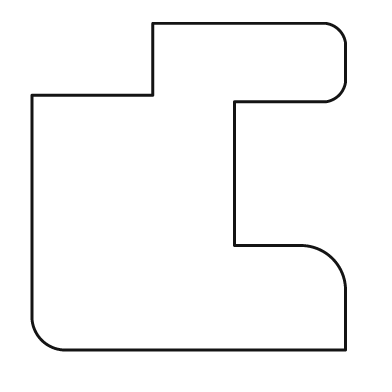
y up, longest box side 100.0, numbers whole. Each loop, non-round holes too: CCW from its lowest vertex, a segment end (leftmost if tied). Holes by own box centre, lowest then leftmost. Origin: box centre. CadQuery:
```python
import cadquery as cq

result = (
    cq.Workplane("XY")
    .moveTo(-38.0, -50.0)
    .lineTo(48.0, -50.0)
    .lineTo(48.0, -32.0)
    .threePointArc((44.0, -22.0), (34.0, -18.0))
    .lineTo(14.0, -18.0)
    .lineTo(14.0, 26.0)
    .lineTo(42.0, 26.0)
    .threePointArc((46.0, 28.0), (48.0, 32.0))
    .lineTo(48.0, 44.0)
    .threePointArc((46.0, 48.0), (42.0, 50.0))
    .lineTo(-11.0, 50.0)
    .lineTo(-11.0, 28.0)
    .lineTo(-48.0, 28.0)
    .lineTo(-48.0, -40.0)
    .threePointArc((-45.0, -47.0), (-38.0, -50.0))
    .close()
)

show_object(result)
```